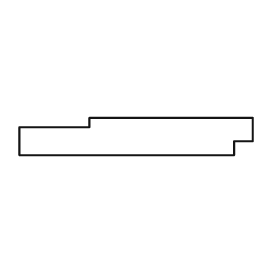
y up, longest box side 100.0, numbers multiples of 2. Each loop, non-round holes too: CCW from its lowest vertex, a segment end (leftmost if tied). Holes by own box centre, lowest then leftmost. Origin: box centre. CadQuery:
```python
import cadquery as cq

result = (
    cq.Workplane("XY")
    .moveTo(-50.0, -8.0)
    .lineTo(42.0, -8.0)
    .lineTo(42.0, -2.0)
    .lineTo(50.0, -2.0)
    .lineTo(50.0, 8.0)
    .lineTo(-20.0, 8.0)
    .lineTo(-20.0, 4.0)
    .lineTo(-50.0, 4.0)
    .close()
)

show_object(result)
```